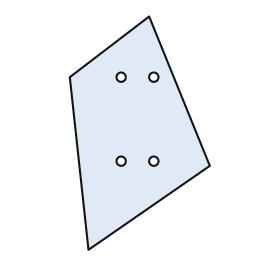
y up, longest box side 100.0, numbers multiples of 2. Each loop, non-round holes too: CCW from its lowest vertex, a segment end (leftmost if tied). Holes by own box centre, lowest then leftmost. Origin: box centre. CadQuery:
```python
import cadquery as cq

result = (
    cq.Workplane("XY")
    .moveTo(-22.0, -50.0)
    .lineTo(30.0, -14.0)
    .lineTo(4.0, 50.0)
    .lineTo(-30.0, 24.0)
    .close()
    .moveTo(-8.0, -12.0)
    .circle(2.0)
    .moveTo(6.0, -12.0)
    .circle(2.0)
    .moveTo(-8.0, 24.0)
    .circle(2.0)
    .moveTo(6.0, 24.0)
    .circle(2.0)
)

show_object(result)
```